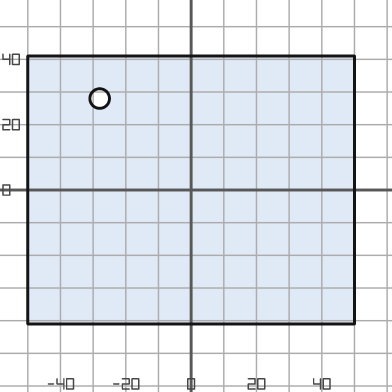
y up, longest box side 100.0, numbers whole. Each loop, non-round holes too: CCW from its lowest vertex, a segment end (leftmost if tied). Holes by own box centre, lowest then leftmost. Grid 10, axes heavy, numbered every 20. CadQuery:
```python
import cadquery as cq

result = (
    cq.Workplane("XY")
    .moveTo(-50.0, -41.0)
    .lineTo(50.0, -41.0)
    .lineTo(50.0, 41.0)
    .lineTo(-50.0, 41.0)
    .close()
    .moveTo(-28.0, 28.0)
    .circle(3.0)
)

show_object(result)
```